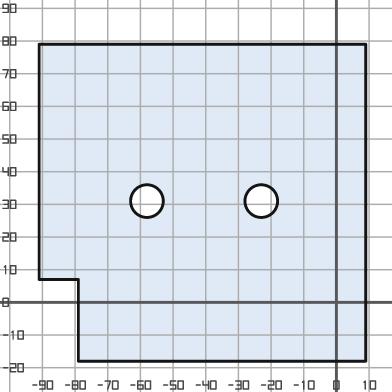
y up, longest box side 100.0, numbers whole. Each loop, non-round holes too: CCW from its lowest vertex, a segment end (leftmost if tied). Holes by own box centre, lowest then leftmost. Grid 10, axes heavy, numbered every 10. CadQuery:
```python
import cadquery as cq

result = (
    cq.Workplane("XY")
    .moveTo(-79.0, -18.0)
    .lineTo(9.0, -18.0)
    .lineTo(9.0, 79.0)
    .lineTo(-91.0, 79.0)
    .lineTo(-91.0, 7.0)
    .lineTo(-79.0, 7.0)
    .close()
    .moveTo(-58.0, 31.0)
    .circle(5.0)
    .moveTo(-23.0, 31.0)
    .circle(5.0)
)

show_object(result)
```